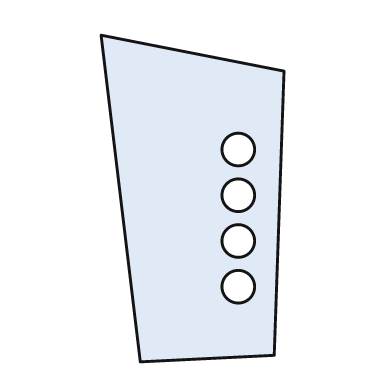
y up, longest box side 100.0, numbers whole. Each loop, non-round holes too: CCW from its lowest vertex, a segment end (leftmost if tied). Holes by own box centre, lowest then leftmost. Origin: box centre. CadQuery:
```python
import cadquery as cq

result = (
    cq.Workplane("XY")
    .moveTo(-16.0, -50.0)
    .lineTo(25.0, -48.0)
    .lineTo(28.0, 39.0)
    .lineTo(-28.0, 50.0)
    .close()
    .moveTo(14.0, -27.0)
    .circle(5.0)
    .moveTo(14.0, -13.0)
    .circle(5.0)
    .moveTo(14.0, 1.0)
    .circle(5.0)
    .moveTo(14.0, 15.0)
    .circle(5.0)
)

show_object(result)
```